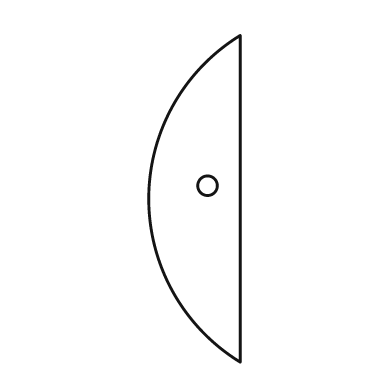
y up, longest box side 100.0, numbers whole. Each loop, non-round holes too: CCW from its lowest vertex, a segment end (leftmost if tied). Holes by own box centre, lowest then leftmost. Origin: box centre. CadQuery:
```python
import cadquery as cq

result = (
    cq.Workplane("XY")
    .moveTo(14.0, -50.0)
    .lineTo(14.0, 50.0)
    .threePointArc((-14.0, 0.0), (14.0, -50.0))
    .close()
    .moveTo(4.0, 4.0)
    .circle(3.0)
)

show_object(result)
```